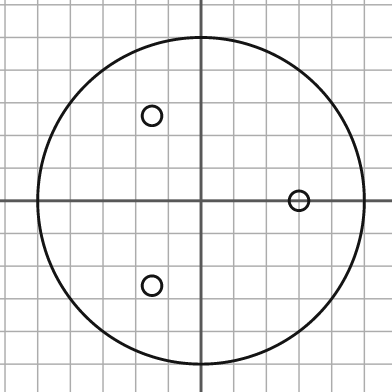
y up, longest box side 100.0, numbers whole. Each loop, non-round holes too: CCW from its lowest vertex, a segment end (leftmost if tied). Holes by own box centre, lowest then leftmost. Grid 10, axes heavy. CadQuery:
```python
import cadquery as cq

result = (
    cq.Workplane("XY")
    .moveTo(0.0, 0.0)
    .circle(50.0)
    .moveTo(-15.0, -26.0)
    .circle(3.0)
    .moveTo(30.0, 0.0)
    .circle(3.0)
    .moveTo(-15.0, 26.0)
    .circle(3.0)
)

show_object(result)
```